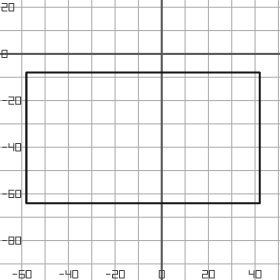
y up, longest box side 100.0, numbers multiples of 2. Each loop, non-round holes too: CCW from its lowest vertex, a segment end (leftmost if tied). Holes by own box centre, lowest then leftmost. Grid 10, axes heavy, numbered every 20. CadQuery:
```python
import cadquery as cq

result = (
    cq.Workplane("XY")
    .moveTo(-58.0, -64.0)
    .lineTo(42.0, -64.0)
    .lineTo(42.0, -8.0)
    .lineTo(-58.0, -8.0)
    .close()
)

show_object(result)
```